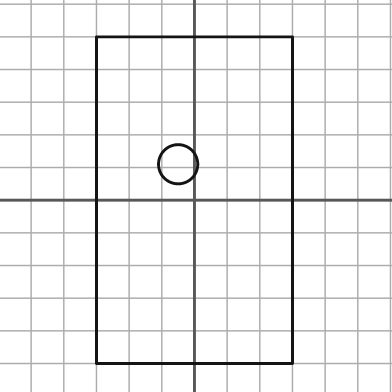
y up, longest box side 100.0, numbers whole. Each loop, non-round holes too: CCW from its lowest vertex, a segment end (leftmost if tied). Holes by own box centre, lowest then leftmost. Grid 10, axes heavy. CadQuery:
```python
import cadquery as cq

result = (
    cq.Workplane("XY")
    .moveTo(-30.0, -50.0)
    .lineTo(30.0, -50.0)
    .lineTo(30.0, 50.0)
    .lineTo(-30.0, 50.0)
    .close()
    .moveTo(-5.0, 11.0)
    .circle(6.0)
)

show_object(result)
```